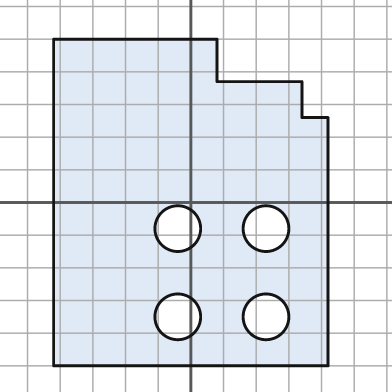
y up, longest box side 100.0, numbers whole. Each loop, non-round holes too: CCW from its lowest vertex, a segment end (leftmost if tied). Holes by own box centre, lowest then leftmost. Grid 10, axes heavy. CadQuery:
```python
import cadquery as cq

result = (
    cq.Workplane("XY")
    .moveTo(-42.0, -50.0)
    .lineTo(42.0, -50.0)
    .lineTo(42.0, 26.0)
    .lineTo(34.0, 26.0)
    .lineTo(34.0, 37.0)
    .lineTo(8.0, 37.0)
    .lineTo(8.0, 50.0)
    .lineTo(-42.0, 50.0)
    .close()
    .moveTo(-4.0, -35.0)
    .circle(7.0)
    .moveTo(23.0, -35.0)
    .circle(7.0)
    .moveTo(-4.0, -8.0)
    .circle(7.0)
    .moveTo(23.0, -8.0)
    .circle(7.0)
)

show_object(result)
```